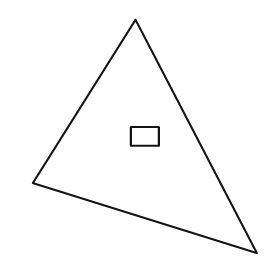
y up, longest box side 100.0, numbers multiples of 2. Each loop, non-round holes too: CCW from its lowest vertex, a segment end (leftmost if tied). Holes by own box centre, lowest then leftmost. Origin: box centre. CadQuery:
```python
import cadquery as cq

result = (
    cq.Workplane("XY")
    .moveTo(48.0, -50.0)
    .lineTo(-4.0, 50.0)
    .lineTo(-48.0, -20.0)
    .close()
    .moveTo(-6.0, -4.0)
    .lineTo(6.0, -4.0)
    .lineTo(6.0, 4.0)
    .lineTo(-6.0, 4.0)
    .close()
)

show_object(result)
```